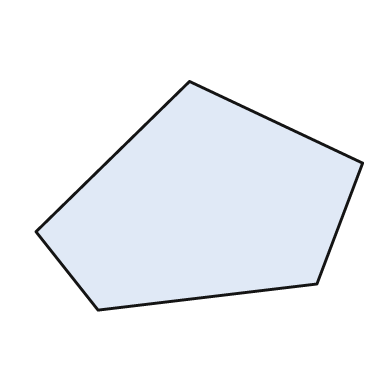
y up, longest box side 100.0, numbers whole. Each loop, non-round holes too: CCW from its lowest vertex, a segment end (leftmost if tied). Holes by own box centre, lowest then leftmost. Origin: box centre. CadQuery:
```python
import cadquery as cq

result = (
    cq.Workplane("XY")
    .moveTo(-31.0, -35.0)
    .lineTo(36.0, -27.0)
    .lineTo(50.0, 10.0)
    .lineTo(-3.0, 35.0)
    .lineTo(-50.0, -11.0)
    .close()
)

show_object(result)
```